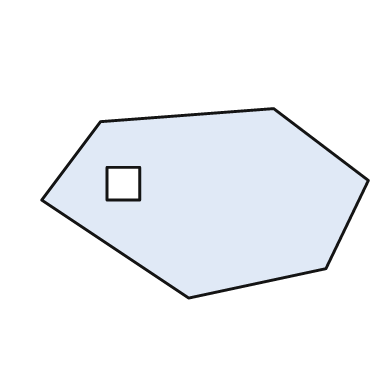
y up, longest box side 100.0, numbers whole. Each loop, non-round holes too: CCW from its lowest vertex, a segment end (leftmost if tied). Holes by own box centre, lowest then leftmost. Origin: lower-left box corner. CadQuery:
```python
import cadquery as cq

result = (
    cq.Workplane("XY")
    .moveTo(45.0, 0.0)
    .lineTo(87.0, 9.0)
    .lineTo(100.0, 36.0)
    .lineTo(71.0, 58.0)
    .lineTo(18.0, 54.0)
    .lineTo(0.0, 30.0)
    .close()
    .moveTo(20.0, 30.0)
    .lineTo(30.0, 30.0)
    .lineTo(30.0, 40.0)
    .lineTo(20.0, 40.0)
    .close()
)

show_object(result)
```